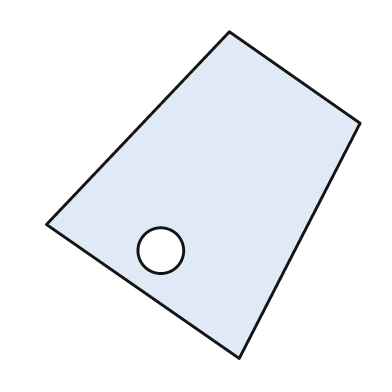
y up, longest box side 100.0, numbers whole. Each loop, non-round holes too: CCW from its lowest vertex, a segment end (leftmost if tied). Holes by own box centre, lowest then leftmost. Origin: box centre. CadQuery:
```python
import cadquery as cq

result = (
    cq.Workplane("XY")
    .moveTo(11.0, -50.0)
    .lineTo(48.0, 22.0)
    .lineTo(8.0, 50.0)
    .lineTo(-48.0, -9.0)
    .close()
    .moveTo(-13.0, -17.0)
    .circle(7.0)
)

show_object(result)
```